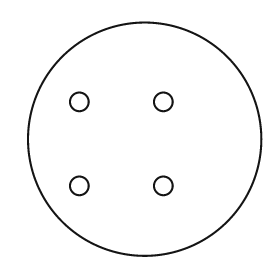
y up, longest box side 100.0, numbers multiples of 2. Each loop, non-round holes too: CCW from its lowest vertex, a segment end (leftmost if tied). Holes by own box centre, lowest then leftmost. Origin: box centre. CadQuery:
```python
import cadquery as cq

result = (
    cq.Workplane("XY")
    .moveTo(0.0, 0.0)
    .circle(50.0)
    .moveTo(-28.0, -20.0)
    .circle(4.0)
    .moveTo(8.0, -20.0)
    .circle(4.0)
    .moveTo(-28.0, 16.0)
    .circle(4.0)
    .moveTo(8.0, 16.0)
    .circle(4.0)
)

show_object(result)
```